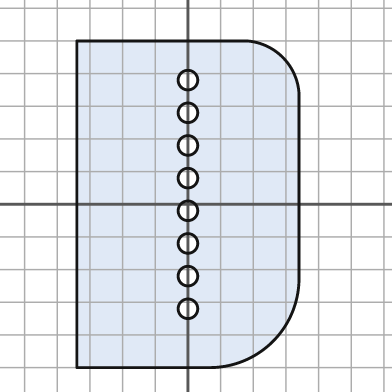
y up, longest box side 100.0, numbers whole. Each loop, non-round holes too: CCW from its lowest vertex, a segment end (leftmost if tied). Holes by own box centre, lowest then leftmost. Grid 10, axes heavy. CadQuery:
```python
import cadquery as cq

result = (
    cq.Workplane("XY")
    .moveTo(-34.0, -50.0)
    .lineTo(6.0, -50.0)
    .threePointArc((26.0, -42.0), (34.0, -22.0))
    .lineTo(34.0, 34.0)
    .threePointArc((29.0, 45.0), (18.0, 50.0))
    .lineTo(-34.0, 50.0)
    .close()
    .moveTo(0.0, -32.0)
    .circle(3.0)
    .moveTo(0.0, -22.0)
    .circle(3.0)
    .moveTo(0.0, -12.0)
    .circle(3.0)
    .moveTo(0.0, -2.0)
    .circle(3.0)
    .moveTo(0.0, 8.0)
    .circle(3.0)
    .moveTo(0.0, 18.0)
    .circle(3.0)
    .moveTo(0.0, 28.0)
    .circle(3.0)
    .moveTo(0.0, 38.0)
    .circle(3.0)
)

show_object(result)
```